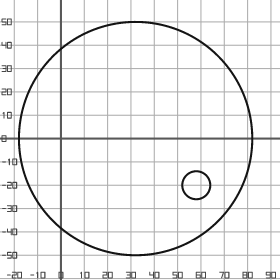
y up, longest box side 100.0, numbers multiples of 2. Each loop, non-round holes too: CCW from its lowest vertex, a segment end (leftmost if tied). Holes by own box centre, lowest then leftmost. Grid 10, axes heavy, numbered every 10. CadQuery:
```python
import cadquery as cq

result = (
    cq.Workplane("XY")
    .moveTo(32.0, 0.0)
    .circle(50.0)
    .moveTo(58.0, -20.0)
    .circle(6.0)
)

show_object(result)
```